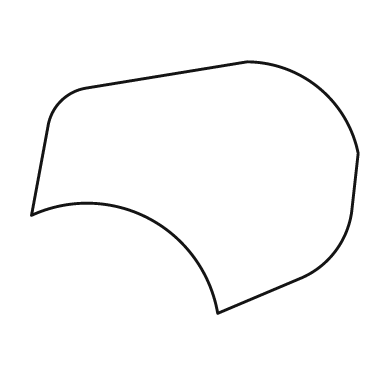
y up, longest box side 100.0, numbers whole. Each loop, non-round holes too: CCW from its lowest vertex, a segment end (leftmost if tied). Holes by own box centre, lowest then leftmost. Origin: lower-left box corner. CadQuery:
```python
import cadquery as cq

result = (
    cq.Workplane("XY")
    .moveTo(57.0, 0.0)
    .lineTo(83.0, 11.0)
    .threePointArc((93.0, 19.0), (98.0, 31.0))
    .lineTo(100.0, 49.0)
    .threePointArc((88.0, 69.0), (66.0, 77.0))
    .lineTo(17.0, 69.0)
    .threePointArc((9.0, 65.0), (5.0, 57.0))
    .lineTo(0.0, 30.0)
    .threePointArc((36.0, 29.0), (57.0, 0.0))
    .close()
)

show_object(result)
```